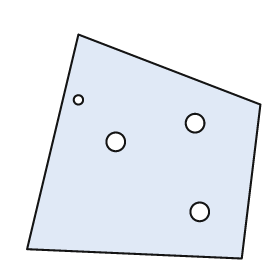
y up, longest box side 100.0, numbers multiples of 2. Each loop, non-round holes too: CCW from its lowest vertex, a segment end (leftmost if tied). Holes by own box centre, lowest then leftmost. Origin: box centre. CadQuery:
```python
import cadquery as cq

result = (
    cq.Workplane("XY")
    .moveTo(42.0, -48.0)
    .lineTo(50.0, 18.0)
    .lineTo(-28.0, 48.0)
    .lineTo(-50.0, -44.0)
    .close()
    .moveTo(24.0, -28.0)
    .circle(4.0)
    .moveTo(-12.0, 2.0)
    .circle(4.0)
    .moveTo(22.0, 10.0)
    .circle(4.0)
    .moveTo(-28.0, 20.0)
    .circle(2.0)
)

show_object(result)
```